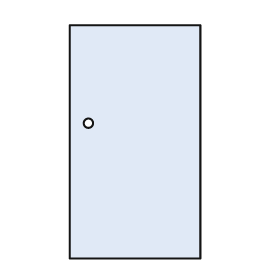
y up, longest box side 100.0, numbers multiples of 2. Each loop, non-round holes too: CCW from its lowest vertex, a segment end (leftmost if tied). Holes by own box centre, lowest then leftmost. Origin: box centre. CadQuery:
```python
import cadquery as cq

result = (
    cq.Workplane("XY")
    .moveTo(-28.0, -50.0)
    .lineTo(28.0, -50.0)
    .lineTo(28.0, 50.0)
    .lineTo(-28.0, 50.0)
    .close()
    .moveTo(-20.0, 8.0)
    .circle(2.0)
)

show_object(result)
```